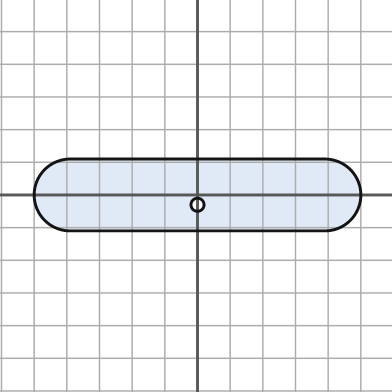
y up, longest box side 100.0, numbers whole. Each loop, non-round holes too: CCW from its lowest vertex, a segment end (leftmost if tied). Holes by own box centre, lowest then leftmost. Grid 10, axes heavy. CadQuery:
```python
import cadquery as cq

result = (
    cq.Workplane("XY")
    .moveTo(-39.0, -11.0)
    .lineTo(39.0, -11.0)
    .threePointArc((50.0, 0.0), (39.0, 11.0))
    .lineTo(-39.0, 11.0)
    .threePointArc((-50.0, 0.0), (-39.0, -11.0))
    .close()
    .moveTo(0.0, -3.0)
    .circle(2.0)
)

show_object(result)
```